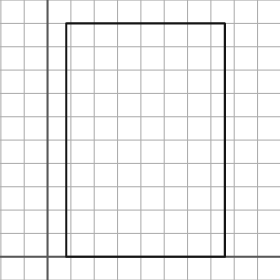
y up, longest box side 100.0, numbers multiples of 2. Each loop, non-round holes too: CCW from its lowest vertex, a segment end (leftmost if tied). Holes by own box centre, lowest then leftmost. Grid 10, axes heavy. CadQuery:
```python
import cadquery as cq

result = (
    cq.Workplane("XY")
    .moveTo(8.0, 0.0)
    .lineTo(76.0, 0.0)
    .lineTo(76.0, 100.0)
    .lineTo(8.0, 100.0)
    .close()
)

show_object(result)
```